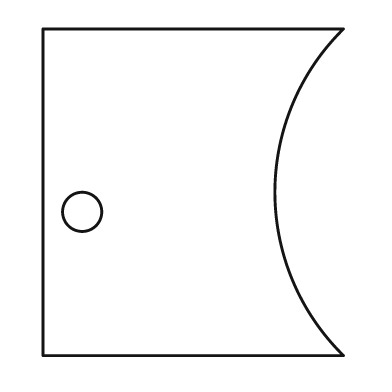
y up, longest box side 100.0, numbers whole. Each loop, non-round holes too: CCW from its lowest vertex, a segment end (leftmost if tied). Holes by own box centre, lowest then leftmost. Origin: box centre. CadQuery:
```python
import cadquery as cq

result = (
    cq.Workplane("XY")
    .moveTo(-46.0, -50.0)
    .lineTo(46.0, -50.0)
    .threePointArc((25.0, 0.0), (46.0, 50.0))
    .lineTo(-46.0, 50.0)
    .close()
    .moveTo(-34.0, -6.0)
    .circle(6.0)
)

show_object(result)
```